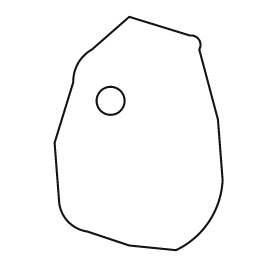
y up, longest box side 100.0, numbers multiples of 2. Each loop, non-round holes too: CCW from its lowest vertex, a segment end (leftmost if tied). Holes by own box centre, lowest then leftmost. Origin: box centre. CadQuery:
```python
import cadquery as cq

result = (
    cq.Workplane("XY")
    .moveTo(16.0, -50.0)
    .threePointArc((30.0, -38.0), (36.0, -20.0))
    .lineTo(34.0, 6.0)
    .lineTo(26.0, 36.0)
    .threePointArc((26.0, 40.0), (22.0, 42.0))
    .lineTo(-4.0, 50.0)
    .lineTo(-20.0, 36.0)
    .threePointArc((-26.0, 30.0), (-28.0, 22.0))
    .lineTo(-36.0, -4.0)
    .lineTo(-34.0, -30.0)
    .threePointArc((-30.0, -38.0), (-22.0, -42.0))
    .lineTo(-4.0, -48.0)
    .close()
    .moveTo(-12.0, 14.0)
    .circle(6.0)
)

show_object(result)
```